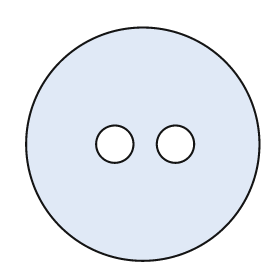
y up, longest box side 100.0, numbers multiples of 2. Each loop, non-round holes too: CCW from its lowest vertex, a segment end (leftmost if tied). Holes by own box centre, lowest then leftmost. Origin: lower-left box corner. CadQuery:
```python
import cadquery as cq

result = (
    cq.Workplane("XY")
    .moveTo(50.0, 50.0)
    .circle(50.0)
    .moveTo(38.0, 50.0)
    .circle(8.0)
    .moveTo(64.0, 50.0)
    .circle(8.0)
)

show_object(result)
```